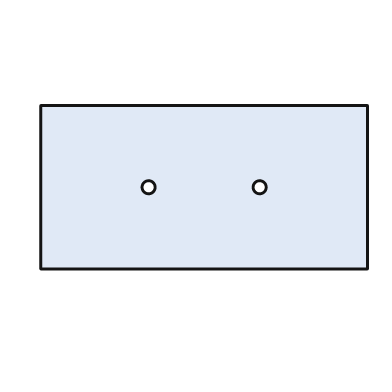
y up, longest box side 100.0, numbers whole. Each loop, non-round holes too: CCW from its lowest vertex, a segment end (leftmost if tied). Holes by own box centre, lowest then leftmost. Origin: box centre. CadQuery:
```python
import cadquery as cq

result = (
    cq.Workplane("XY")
    .moveTo(-50.0, -25.0)
    .lineTo(50.0, -25.0)
    .lineTo(50.0, 25.0)
    .lineTo(-50.0, 25.0)
    .close()
    .moveTo(-17.0, 0.0)
    .circle(2.0)
    .moveTo(17.0, 0.0)
    .circle(2.0)
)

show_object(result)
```